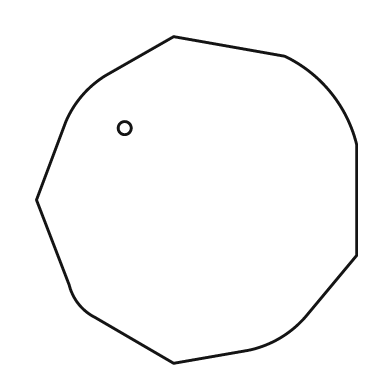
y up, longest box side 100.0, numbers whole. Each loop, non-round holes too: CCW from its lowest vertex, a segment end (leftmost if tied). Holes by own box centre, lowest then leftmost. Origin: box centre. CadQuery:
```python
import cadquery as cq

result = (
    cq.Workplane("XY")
    .moveTo(-7.0, -50.0)
    .lineTo(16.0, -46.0)
    .threePointArc((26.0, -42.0), (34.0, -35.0))
    .lineTo(49.0, -17.0)
    .lineTo(49.0, 17.0)
    .threePointArc((41.0, 33.0), (27.0, 44.0))
    .lineTo(-7.0, 50.0)
    .lineTo(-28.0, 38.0)
    .threePointArc((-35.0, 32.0), (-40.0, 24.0))
    .lineTo(-49.0, 0.0)
    .lineTo(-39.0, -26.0)
    .threePointArc((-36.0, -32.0), (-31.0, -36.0))
    .close()
    .moveTo(-22.0, 22.0)
    .circle(2.0)
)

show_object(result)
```